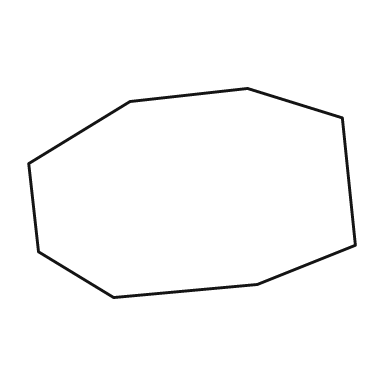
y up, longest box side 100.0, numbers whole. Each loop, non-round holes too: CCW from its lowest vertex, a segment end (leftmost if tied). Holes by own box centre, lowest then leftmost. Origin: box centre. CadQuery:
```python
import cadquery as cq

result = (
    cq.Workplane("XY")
    .moveTo(-24.0, -32.0)
    .lineTo(20.0, -28.0)
    .lineTo(50.0, -16.0)
    .lineTo(46.0, 23.0)
    .lineTo(17.0, 32.0)
    .lineTo(-19.0, 28.0)
    .lineTo(-50.0, 9.0)
    .lineTo(-47.0, -18.0)
    .close()
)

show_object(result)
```